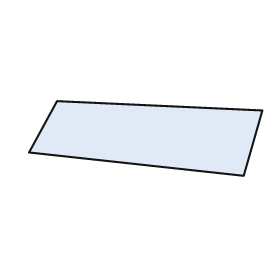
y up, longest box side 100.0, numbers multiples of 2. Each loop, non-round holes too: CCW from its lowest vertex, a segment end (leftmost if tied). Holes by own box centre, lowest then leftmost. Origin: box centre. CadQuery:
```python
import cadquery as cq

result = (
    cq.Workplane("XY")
    .moveTo(42.0, -16.0)
    .lineTo(50.0, 12.0)
    .lineTo(-38.0, 16.0)
    .lineTo(-50.0, -6.0)
    .close()
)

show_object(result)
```